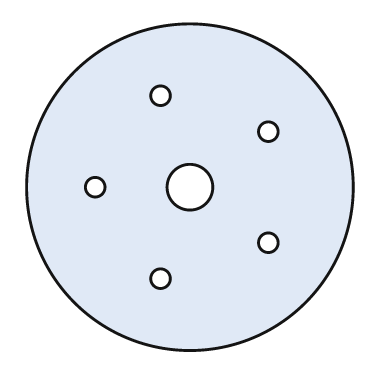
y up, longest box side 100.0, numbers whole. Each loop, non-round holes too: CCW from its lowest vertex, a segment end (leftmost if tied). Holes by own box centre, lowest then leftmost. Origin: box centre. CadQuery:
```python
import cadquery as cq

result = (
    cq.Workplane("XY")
    .moveTo(0.0, 0.0)
    .circle(50.0)
    .moveTo(-9.0, -28.0)
    .circle(3.0)
    .moveTo(24.0, -17.0)
    .circle(3.0)
    .moveTo(-29.0, 0.0)
    .circle(3.0)
    .moveTo(0.0, 0.0)
    .circle(7.0)
    .moveTo(24.0, 17.0)
    .circle(3.0)
    .moveTo(-9.0, 28.0)
    .circle(3.0)
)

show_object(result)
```